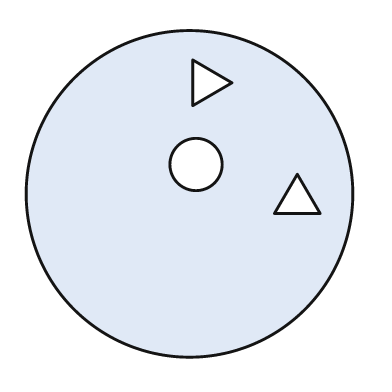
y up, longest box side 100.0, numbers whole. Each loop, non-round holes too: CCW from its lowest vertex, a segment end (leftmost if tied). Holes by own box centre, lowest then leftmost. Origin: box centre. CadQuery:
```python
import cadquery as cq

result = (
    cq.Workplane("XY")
    .moveTo(0.0, 0.0)
    .circle(50.0)
    .moveTo(26.0, -6.0)
    .lineTo(40.0, -6.0)
    .lineTo(33.0, 6.0)
    .close()
    .moveTo(2.0, 9.0)
    .circle(8.0)
    .moveTo(1.0, 27.0)
    .lineTo(13.0, 34.0)
    .lineTo(1.0, 41.0)
    .close()
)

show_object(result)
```